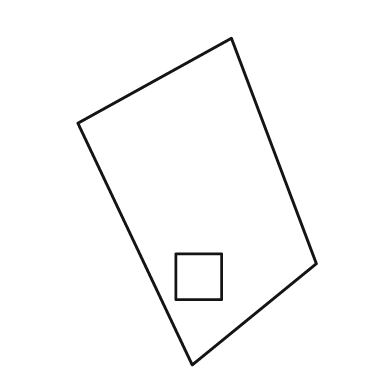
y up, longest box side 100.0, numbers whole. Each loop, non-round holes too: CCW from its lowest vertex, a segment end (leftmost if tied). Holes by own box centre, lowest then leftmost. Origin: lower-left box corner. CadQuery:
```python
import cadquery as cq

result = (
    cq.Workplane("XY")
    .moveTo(35.0, 0.0)
    .lineTo(73.0, 31.0)
    .lineTo(47.0, 100.0)
    .lineTo(0.0, 74.0)
    .close()
    .moveTo(30.0, 20.0)
    .lineTo(44.0, 20.0)
    .lineTo(44.0, 34.0)
    .lineTo(30.0, 34.0)
    .close()
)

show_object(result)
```